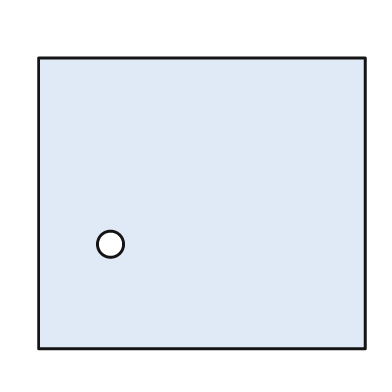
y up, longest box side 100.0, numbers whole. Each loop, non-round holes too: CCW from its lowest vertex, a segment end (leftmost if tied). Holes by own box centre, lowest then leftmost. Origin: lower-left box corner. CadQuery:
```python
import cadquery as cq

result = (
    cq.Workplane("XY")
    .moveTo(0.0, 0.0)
    .lineTo(100.0, 0.0)
    .lineTo(100.0, 89.0)
    .lineTo(0.0, 89.0)
    .close()
    .moveTo(22.0, 32.0)
    .circle(4.0)
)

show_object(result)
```